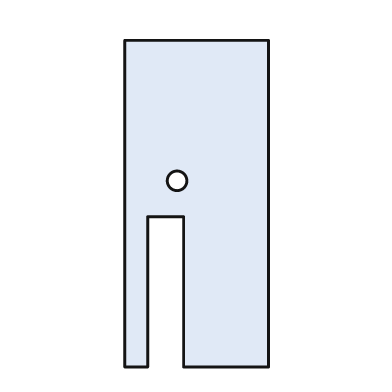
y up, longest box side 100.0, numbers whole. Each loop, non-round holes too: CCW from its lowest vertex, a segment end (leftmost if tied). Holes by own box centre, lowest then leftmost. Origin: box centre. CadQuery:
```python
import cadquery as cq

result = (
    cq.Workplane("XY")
    .moveTo(-22.0, -50.0)
    .lineTo(-15.0, -50.0)
    .lineTo(-15.0, -4.0)
    .lineTo(-4.0, -4.0)
    .lineTo(-4.0, -50.0)
    .lineTo(22.0, -50.0)
    .lineTo(22.0, 50.0)
    .lineTo(-22.0, 50.0)
    .close()
    .moveTo(-6.0, 7.0)
    .circle(3.0)
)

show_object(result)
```